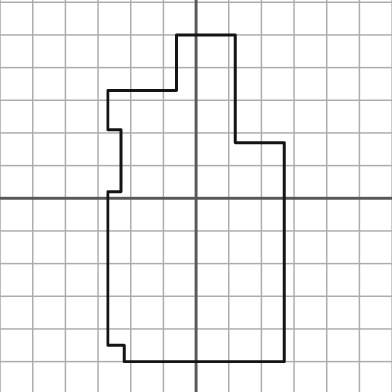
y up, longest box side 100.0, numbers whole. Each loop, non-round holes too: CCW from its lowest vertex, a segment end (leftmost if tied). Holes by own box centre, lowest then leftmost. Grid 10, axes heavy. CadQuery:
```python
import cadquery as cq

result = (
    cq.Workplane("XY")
    .moveTo(-22.0, -50.0)
    .lineTo(27.0, -50.0)
    .lineTo(27.0, 17.0)
    .lineTo(12.0, 17.0)
    .lineTo(12.0, 50.0)
    .lineTo(-6.0, 50.0)
    .lineTo(-6.0, 33.0)
    .lineTo(-27.0, 33.0)
    .lineTo(-27.0, 21.0)
    .lineTo(-23.0, 21.0)
    .lineTo(-23.0, 2.0)
    .lineTo(-27.0, 2.0)
    .lineTo(-27.0, -45.0)
    .lineTo(-22.0, -45.0)
    .close()
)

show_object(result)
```